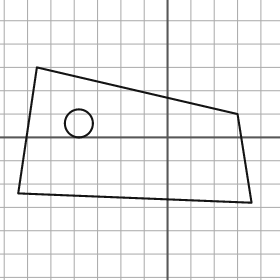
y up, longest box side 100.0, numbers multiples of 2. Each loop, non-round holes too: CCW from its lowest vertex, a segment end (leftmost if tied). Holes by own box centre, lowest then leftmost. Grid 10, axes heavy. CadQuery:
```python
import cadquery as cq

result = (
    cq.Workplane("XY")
    .moveTo(36.0, -28.0)
    .lineTo(30.0, 10.0)
    .lineTo(-56.0, 30.0)
    .lineTo(-64.0, -24.0)
    .close()
    .moveTo(-38.0, 6.0)
    .circle(6.0)
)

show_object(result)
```